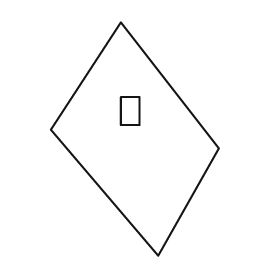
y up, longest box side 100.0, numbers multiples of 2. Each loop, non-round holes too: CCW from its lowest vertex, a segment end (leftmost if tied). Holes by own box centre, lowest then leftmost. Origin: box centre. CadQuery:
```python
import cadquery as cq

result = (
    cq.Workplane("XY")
    .moveTo(10.0, -50.0)
    .lineTo(36.0, -4.0)
    .lineTo(-6.0, 50.0)
    .lineTo(-36.0, 4.0)
    .close()
    .moveTo(-6.0, 6.0)
    .lineTo(2.0, 6.0)
    .lineTo(2.0, 18.0)
    .lineTo(-6.0, 18.0)
    .close()
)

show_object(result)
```